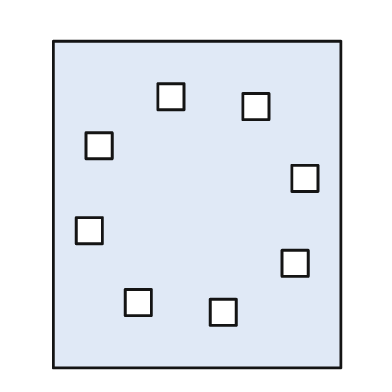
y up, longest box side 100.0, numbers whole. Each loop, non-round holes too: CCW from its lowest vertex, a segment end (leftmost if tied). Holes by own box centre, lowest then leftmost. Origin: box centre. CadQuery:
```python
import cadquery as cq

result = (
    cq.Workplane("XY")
    .moveTo(-44.0, -50.0)
    .lineTo(44.0, -50.0)
    .lineTo(44.0, 50.0)
    .lineTo(-44.0, 50.0)
    .close()
    .moveTo(4.0, -37.0)
    .lineTo(12.0, -37.0)
    .lineTo(12.0, -29.0)
    .lineTo(4.0, -29.0)
    .close()
    .moveTo(-22.0, -34.0)
    .lineTo(-14.0, -34.0)
    .lineTo(-14.0, -26.0)
    .lineTo(-22.0, -26.0)
    .close()
    .moveTo(26.0, -22.0)
    .lineTo(34.0, -22.0)
    .lineTo(34.0, -14.0)
    .lineTo(26.0, -14.0)
    .close()
    .moveTo(-37.0, -12.0)
    .lineTo(-29.0, -12.0)
    .lineTo(-29.0, -4.0)
    .lineTo(-37.0, -4.0)
    .close()
    .moveTo(29.0, 4.0)
    .lineTo(37.0, 4.0)
    .lineTo(37.0, 12.0)
    .lineTo(29.0, 12.0)
    .close()
    .moveTo(-34.0, 14.0)
    .lineTo(-26.0, 14.0)
    .lineTo(-26.0, 22.0)
    .lineTo(-34.0, 22.0)
    .close()
    .moveTo(14.0, 26.0)
    .lineTo(22.0, 26.0)
    .lineTo(22.0, 34.0)
    .lineTo(14.0, 34.0)
    .close()
    .moveTo(-12.0, 29.0)
    .lineTo(-4.0, 29.0)
    .lineTo(-4.0, 37.0)
    .lineTo(-12.0, 37.0)
    .close()
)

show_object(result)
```